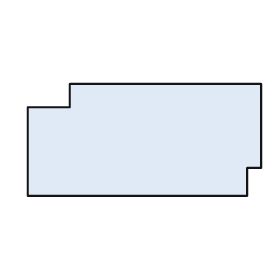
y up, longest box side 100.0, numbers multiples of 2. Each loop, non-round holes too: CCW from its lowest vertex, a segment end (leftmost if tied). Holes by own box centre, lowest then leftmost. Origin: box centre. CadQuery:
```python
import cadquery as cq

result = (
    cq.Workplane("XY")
    .moveTo(-50.0, -24.0)
    .lineTo(44.0, -24.0)
    .lineTo(44.0, -12.0)
    .lineTo(50.0, -12.0)
    .lineTo(50.0, 24.0)
    .lineTo(-32.0, 24.0)
    .lineTo(-32.0, 14.0)
    .lineTo(-50.0, 14.0)
    .close()
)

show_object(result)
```